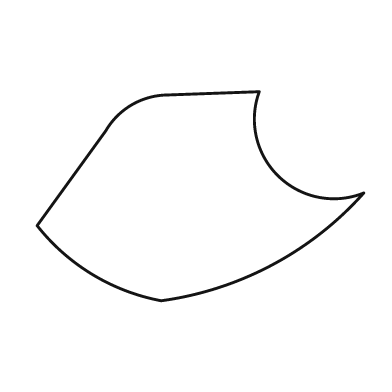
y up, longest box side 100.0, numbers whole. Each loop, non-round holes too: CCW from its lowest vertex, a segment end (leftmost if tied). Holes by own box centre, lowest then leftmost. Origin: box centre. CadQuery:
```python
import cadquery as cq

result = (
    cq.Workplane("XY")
    .moveTo(-12.0, -32.0)
    .threePointArc((22.0, -21.0), (50.0, 1.0))
    .threePointArc((24.0, 6.0), (18.0, 32.0))
    .lineTo(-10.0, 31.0)
    .threePointArc((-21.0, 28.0), (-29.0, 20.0))
    .lineTo(-50.0, -9.0)
    .threePointArc((-33.0, -24.0), (-12.0, -32.0))
    .close()
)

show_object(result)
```